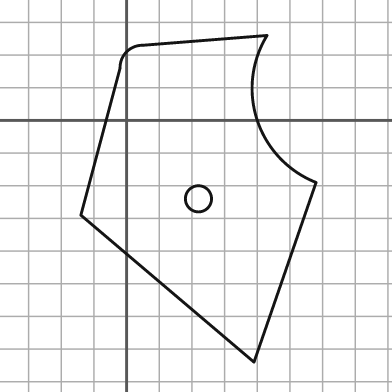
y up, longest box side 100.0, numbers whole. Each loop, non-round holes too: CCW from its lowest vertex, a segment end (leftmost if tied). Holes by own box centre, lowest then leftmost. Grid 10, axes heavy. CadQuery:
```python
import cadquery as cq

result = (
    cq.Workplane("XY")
    .moveTo(39.0, -74.0)
    .lineTo(58.0, -19.0)
    .threePointArc((40.0, 0.0), (43.0, 26.0))
    .lineTo(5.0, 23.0)
    .threePointArc((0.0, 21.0), (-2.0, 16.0))
    .lineTo(-14.0, -29.0)
    .close()
    .moveTo(22.0, -24.0)
    .circle(4.0)
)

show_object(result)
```